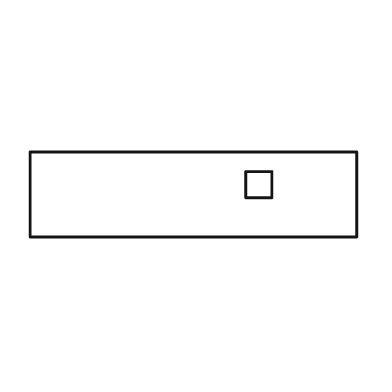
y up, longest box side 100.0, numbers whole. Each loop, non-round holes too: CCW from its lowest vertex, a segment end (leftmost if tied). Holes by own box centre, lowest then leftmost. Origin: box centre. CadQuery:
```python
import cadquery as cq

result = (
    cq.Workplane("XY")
    .moveTo(-50.0, -13.0)
    .lineTo(50.0, -13.0)
    .lineTo(50.0, 13.0)
    .lineTo(-50.0, 13.0)
    .close()
    .moveTo(16.0, -1.0)
    .lineTo(24.0, -1.0)
    .lineTo(24.0, 7.0)
    .lineTo(16.0, 7.0)
    .close()
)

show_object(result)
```